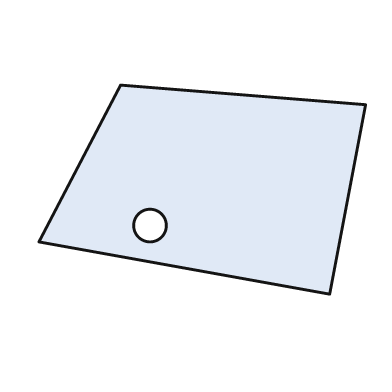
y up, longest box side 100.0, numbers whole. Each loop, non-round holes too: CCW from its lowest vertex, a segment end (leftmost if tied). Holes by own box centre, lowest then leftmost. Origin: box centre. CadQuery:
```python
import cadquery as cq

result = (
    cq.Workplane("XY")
    .moveTo(39.0, -32.0)
    .lineTo(50.0, 26.0)
    .lineTo(-25.0, 32.0)
    .lineTo(-50.0, -16.0)
    .close()
    .moveTo(-16.0, -11.0)
    .circle(5.0)
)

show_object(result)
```